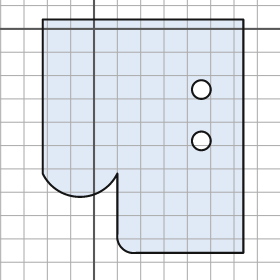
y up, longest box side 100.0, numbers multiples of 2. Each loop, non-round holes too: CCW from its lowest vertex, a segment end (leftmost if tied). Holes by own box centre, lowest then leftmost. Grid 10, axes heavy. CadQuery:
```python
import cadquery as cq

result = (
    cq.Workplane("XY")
    .moveTo(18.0, -96.0)
    .lineTo(64.0, -96.0)
    .lineTo(64.0, 4.0)
    .lineTo(-22.0, 4.0)
    .lineTo(-22.0, -62.0)
    .threePointArc((-6.0, -72.0), (10.0, -62.0))
    .lineTo(10.0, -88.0)
    .threePointArc((12.0, -94.0), (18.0, -96.0))
    .close()
    .moveTo(46.0, -48.0)
    .circle(4.0)
    .moveTo(46.0, -26.0)
    .circle(4.0)
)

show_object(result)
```